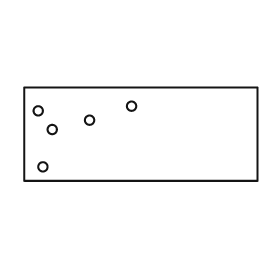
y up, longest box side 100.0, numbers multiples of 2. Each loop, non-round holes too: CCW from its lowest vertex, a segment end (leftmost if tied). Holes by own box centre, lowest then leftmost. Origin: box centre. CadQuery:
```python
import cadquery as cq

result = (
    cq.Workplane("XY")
    .moveTo(-50.0, -20.0)
    .lineTo(50.0, -20.0)
    .lineTo(50.0, 20.0)
    .lineTo(-50.0, 20.0)
    .close()
    .moveTo(-42.0, -14.0)
    .circle(2.0)
    .moveTo(-38.0, 2.0)
    .circle(2.0)
    .moveTo(-22.0, 6.0)
    .circle(2.0)
    .moveTo(-44.0, 10.0)
    .circle(2.0)
    .moveTo(-4.0, 12.0)
    .circle(2.0)
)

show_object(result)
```